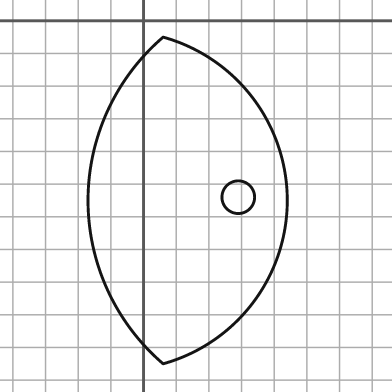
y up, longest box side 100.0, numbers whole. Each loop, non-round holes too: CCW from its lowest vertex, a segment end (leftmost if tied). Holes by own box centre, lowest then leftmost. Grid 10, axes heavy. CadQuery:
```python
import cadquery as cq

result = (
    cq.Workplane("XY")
    .moveTo(6.0, -105.0)
    .threePointArc((44.0, -55.0), (6.0, -5.0))
    .threePointArc((-17.0, -55.0), (6.0, -105.0))
    .close()
    .moveTo(29.0, -54.0)
    .circle(5.0)
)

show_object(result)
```